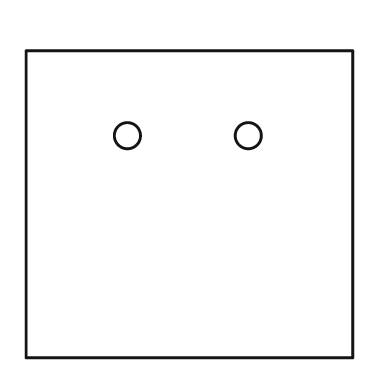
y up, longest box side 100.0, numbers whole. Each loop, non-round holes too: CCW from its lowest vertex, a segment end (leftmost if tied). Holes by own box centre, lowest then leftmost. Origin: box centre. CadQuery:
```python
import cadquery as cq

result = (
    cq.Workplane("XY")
    .moveTo(-50.0, -47.0)
    .lineTo(50.0, -47.0)
    .lineTo(50.0, 47.0)
    .lineTo(-50.0, 47.0)
    .close()
    .moveTo(-19.0, 21.0)
    .circle(4.0)
    .moveTo(18.0, 21.0)
    .circle(4.0)
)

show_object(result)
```